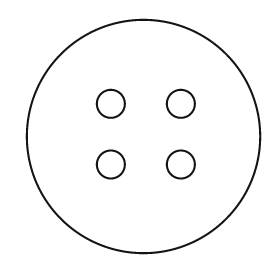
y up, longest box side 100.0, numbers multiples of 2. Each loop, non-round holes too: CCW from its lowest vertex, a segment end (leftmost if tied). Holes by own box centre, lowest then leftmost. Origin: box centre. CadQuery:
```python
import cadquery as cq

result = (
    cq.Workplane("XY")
    .moveTo(0.0, 0.0)
    .circle(50.0)
    .moveTo(-14.0, -12.0)
    .circle(6.0)
    .moveTo(16.0, -12.0)
    .circle(6.0)
    .moveTo(-14.0, 14.0)
    .circle(6.0)
    .moveTo(16.0, 14.0)
    .circle(6.0)
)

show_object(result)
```